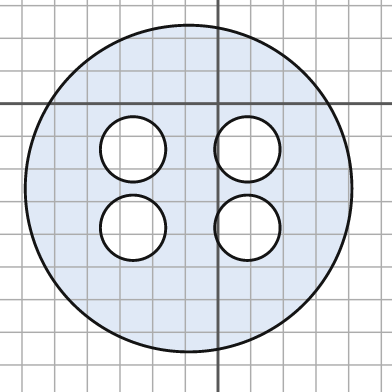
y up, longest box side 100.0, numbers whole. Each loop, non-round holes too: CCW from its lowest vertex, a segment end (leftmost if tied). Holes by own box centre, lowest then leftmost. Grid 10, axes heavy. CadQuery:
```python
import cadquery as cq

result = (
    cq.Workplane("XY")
    .moveTo(-9.0, -26.0)
    .circle(50.0)
    .moveTo(-26.0, -38.0)
    .circle(10.0)
    .moveTo(9.0, -38.0)
    .circle(10.0)
    .moveTo(-26.0, -14.0)
    .circle(10.0)
    .moveTo(9.0, -14.0)
    .circle(10.0)
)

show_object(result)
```